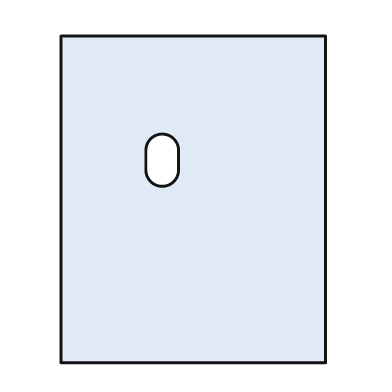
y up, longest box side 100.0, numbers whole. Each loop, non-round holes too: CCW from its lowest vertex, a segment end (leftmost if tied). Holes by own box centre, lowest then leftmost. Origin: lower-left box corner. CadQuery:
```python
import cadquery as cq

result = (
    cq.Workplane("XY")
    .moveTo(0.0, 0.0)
    .lineTo(81.0, 0.0)
    .lineTo(81.0, 100.0)
    .lineTo(0.0, 100.0)
    .close()
    .moveTo(26.0, 59.0)
    .threePointArc((31.0, 54.0), (36.0, 59.0))
    .lineTo(36.0, 65.0)
    .threePointArc((31.0, 70.0), (26.0, 65.0))
    .close()
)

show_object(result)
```